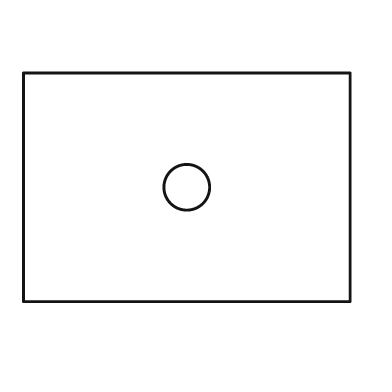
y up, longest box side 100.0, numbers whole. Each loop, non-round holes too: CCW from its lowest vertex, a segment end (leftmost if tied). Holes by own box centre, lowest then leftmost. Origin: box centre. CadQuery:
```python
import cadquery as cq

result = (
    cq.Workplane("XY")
    .moveTo(-50.0, -35.0)
    .lineTo(50.0, -35.0)
    .lineTo(50.0, 35.0)
    .lineTo(-50.0, 35.0)
    .close()
    .moveTo(0.0, 0.0)
    .circle(7.0)
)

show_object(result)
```